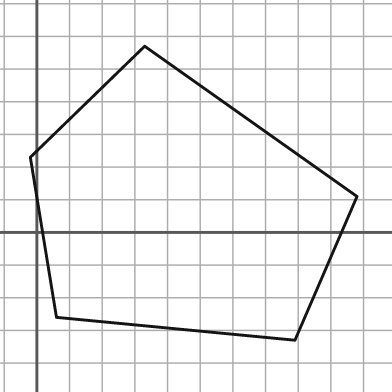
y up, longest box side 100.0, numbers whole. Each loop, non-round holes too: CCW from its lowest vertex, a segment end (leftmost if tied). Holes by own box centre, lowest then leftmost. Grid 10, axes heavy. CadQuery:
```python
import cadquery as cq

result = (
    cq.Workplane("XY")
    .moveTo(79.0, -33.0)
    .lineTo(98.0, 11.0)
    .lineTo(33.0, 57.0)
    .lineTo(-2.0, 23.0)
    .lineTo(6.0, -26.0)
    .close()
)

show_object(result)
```